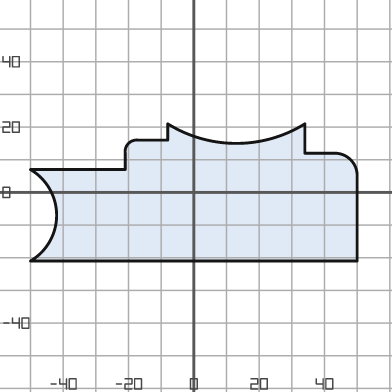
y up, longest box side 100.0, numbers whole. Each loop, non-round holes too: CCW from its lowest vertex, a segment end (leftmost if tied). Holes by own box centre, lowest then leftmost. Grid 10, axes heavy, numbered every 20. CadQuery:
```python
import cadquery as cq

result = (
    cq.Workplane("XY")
    .moveTo(-50.0, -21.0)
    .lineTo(50.0, -21.0)
    .lineTo(50.0, 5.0)
    .threePointArc((48.0, 10.0), (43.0, 12.0))
    .lineTo(34.0, 12.0)
    .lineTo(34.0, 21.0)
    .threePointArc((13.0, 15.0), (-8.0, 21.0))
    .lineTo(-8.0, 16.0)
    .lineTo(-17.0, 16.0)
    .threePointArc((-20.0, 15.0), (-21.0, 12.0))
    .lineTo(-21.0, 7.0)
    .lineTo(-50.0, 7.0)
    .threePointArc((-42.0, -7.0), (-50.0, -21.0))
    .close()
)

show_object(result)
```